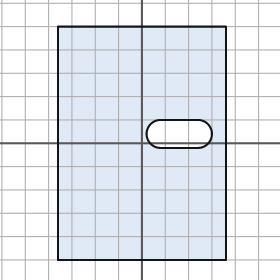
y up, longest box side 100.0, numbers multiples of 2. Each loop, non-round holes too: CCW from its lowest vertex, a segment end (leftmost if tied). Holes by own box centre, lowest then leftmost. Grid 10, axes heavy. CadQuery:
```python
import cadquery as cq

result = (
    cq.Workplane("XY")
    .moveTo(-36.0, -50.0)
    .lineTo(36.0, -50.0)
    .lineTo(36.0, 50.0)
    .lineTo(-36.0, 50.0)
    .close()
    .moveTo(8.0, -2.0)
    .lineTo(24.0, -2.0)
    .threePointArc((30.0, 4.0), (24.0, 10.0))
    .lineTo(8.0, 10.0)
    .threePointArc((2.0, 4.0), (8.0, -2.0))
    .close()
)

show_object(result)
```